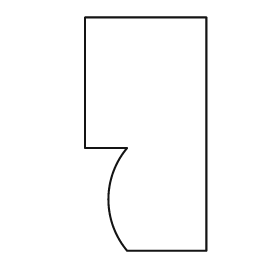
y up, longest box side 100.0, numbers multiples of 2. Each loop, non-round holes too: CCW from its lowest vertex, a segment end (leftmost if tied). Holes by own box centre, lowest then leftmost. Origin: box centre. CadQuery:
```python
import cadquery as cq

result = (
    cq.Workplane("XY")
    .moveTo(-8.0, -50.0)
    .lineTo(26.0, -50.0)
    .lineTo(26.0, 50.0)
    .lineTo(-26.0, 50.0)
    .lineTo(-26.0, -6.0)
    .lineTo(-8.0, -6.0)
    .threePointArc((-16.0, -28.0), (-8.0, -50.0))
    .close()
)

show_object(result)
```